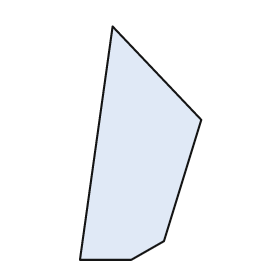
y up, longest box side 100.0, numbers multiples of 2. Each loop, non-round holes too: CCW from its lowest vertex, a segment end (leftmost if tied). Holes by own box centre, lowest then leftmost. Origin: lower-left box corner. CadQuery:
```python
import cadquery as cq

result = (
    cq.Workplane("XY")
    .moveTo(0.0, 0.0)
    .lineTo(22.0, 0.0)
    .lineTo(36.0, 8.0)
    .lineTo(52.0, 60.0)
    .lineTo(14.0, 100.0)
    .close()
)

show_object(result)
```